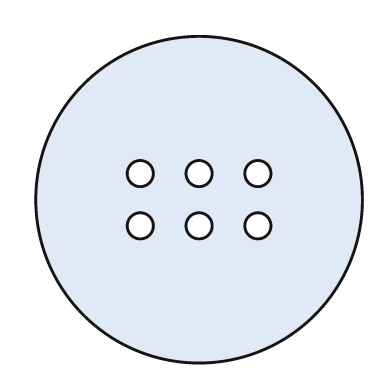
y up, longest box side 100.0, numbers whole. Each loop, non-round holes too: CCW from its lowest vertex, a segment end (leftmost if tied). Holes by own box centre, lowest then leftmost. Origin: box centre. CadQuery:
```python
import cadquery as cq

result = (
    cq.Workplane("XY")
    .moveTo(0.0, 0.0)
    .circle(50.0)
    .moveTo(-18.0, -8.0)
    .circle(4.0)
    .moveTo(0.0, -8.0)
    .circle(4.0)
    .moveTo(18.0, -8.0)
    .circle(4.0)
    .moveTo(-18.0, 8.0)
    .circle(4.0)
    .moveTo(0.0, 8.0)
    .circle(4.0)
    .moveTo(18.0, 8.0)
    .circle(4.0)
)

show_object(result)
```